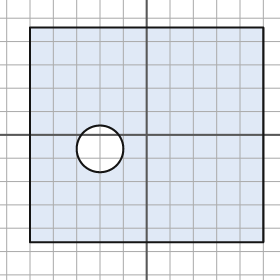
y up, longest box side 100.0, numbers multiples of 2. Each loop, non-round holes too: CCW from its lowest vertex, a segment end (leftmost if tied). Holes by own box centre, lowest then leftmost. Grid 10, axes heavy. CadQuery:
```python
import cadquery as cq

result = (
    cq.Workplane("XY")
    .moveTo(-50.0, -46.0)
    .lineTo(50.0, -46.0)
    .lineTo(50.0, 46.0)
    .lineTo(-50.0, 46.0)
    .close()
    .moveTo(-20.0, -6.0)
    .circle(10.0)
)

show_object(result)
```